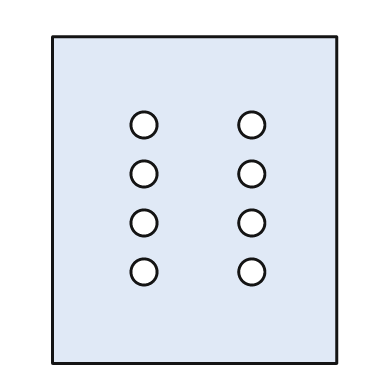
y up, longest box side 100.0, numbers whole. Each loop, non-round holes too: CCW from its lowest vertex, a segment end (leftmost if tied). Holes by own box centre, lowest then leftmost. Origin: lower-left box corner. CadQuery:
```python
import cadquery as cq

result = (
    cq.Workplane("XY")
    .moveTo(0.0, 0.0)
    .lineTo(87.0, 0.0)
    .lineTo(87.0, 100.0)
    .lineTo(0.0, 100.0)
    .close()
    .moveTo(28.0, 28.0)
    .circle(4.0)
    .moveTo(61.0, 28.0)
    .circle(4.0)
    .moveTo(28.0, 43.0)
    .circle(4.0)
    .moveTo(61.0, 43.0)
    .circle(4.0)
    .moveTo(28.0, 58.0)
    .circle(4.0)
    .moveTo(61.0, 58.0)
    .circle(4.0)
    .moveTo(28.0, 73.0)
    .circle(4.0)
    .moveTo(61.0, 73.0)
    .circle(4.0)
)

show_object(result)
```